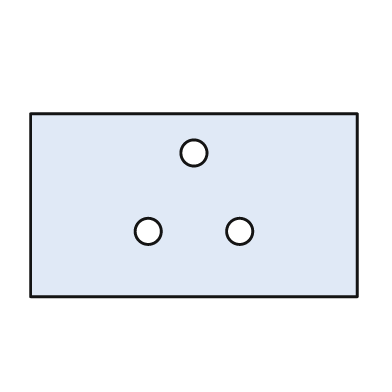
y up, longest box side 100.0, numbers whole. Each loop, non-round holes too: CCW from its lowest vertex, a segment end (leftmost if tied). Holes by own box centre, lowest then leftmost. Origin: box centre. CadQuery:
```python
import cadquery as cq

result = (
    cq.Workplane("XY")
    .moveTo(-50.0, -28.0)
    .lineTo(50.0, -28.0)
    .lineTo(50.0, 28.0)
    .lineTo(-50.0, 28.0)
    .close()
    .moveTo(-14.0, -8.0)
    .circle(4.0)
    .moveTo(14.0, -8.0)
    .circle(4.0)
    .moveTo(0.0, 16.0)
    .circle(4.0)
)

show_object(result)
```